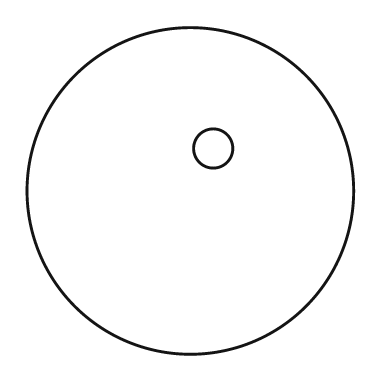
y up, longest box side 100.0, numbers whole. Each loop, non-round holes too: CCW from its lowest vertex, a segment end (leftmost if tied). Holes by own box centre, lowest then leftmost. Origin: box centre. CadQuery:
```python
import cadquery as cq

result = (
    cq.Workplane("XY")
    .moveTo(0.0, 0.0)
    .circle(50.0)
    .moveTo(7.0, 13.0)
    .circle(6.0)
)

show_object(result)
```